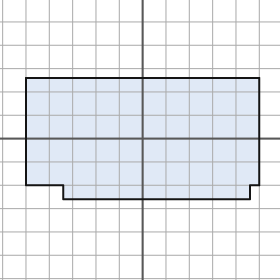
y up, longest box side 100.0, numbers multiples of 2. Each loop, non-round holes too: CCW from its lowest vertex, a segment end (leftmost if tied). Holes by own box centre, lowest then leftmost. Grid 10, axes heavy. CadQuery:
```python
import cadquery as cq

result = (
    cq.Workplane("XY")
    .moveTo(-34.0, -26.0)
    .lineTo(46.0, -26.0)
    .lineTo(46.0, -20.0)
    .lineTo(50.0, -20.0)
    .lineTo(50.0, 26.0)
    .lineTo(-50.0, 26.0)
    .lineTo(-50.0, -20.0)
    .lineTo(-34.0, -20.0)
    .close()
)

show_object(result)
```